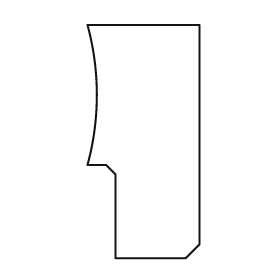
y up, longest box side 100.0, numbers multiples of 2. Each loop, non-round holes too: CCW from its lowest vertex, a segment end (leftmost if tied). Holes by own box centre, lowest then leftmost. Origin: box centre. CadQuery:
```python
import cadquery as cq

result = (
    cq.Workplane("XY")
    .moveTo(-12.0, -50.0)
    .lineTo(18.0, -50.0)
    .lineTo(24.0, -44.0)
    .lineTo(24.0, 50.0)
    .lineTo(-24.0, 50.0)
    .threePointArc((-20.0, 20.0), (-24.0, -10.0))
    .lineTo(-16.0, -10.0)
    .lineTo(-12.0, -14.0)
    .close()
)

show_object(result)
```